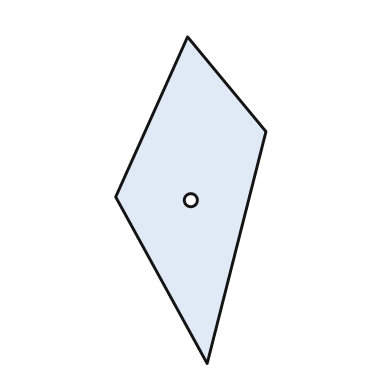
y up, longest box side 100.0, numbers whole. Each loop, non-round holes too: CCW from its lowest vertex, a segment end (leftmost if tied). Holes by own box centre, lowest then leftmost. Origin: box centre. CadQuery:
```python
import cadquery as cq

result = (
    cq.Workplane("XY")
    .moveTo(5.0, -50.0)
    .lineTo(23.0, 21.0)
    .lineTo(-1.0, 50.0)
    .lineTo(-23.0, 1.0)
    .close()
    .moveTo(0.0, 0.0)
    .circle(2.0)
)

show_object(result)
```